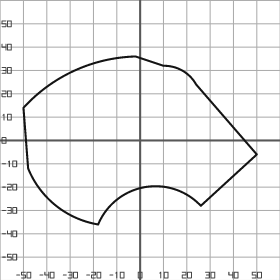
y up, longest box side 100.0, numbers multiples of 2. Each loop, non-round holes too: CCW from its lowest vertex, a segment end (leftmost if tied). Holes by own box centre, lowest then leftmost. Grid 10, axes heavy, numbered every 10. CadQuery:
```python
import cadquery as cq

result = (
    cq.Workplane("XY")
    .moveTo(-18.0, -36.0)
    .threePointArc((2.0, -20.0), (26.0, -28.0))
    .lineTo(50.0, -6.0)
    .lineTo(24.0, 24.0)
    .threePointArc((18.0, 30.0), (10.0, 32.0))
    .lineTo(-2.0, 36.0)
    .threePointArc((-28.0, 30.0), (-50.0, 14.0))
    .lineTo(-48.0, -12.0)
    .threePointArc((-36.0, -28.0), (-18.0, -36.0))
    .close()
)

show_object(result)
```